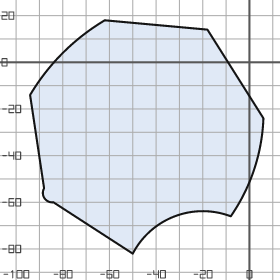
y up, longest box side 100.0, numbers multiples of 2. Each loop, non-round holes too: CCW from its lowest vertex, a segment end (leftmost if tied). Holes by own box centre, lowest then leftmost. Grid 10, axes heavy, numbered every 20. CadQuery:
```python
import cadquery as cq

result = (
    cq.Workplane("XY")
    .moveTo(-50.0, -82.0)
    .threePointArc((-32.0, -66.0), (-8.0, -66.0))
    .threePointArc((2.0, -46.0), (6.0, -24.0))
    .lineTo(-18.0, 14.0)
    .lineTo(-62.0, 18.0)
    .threePointArc((-80.0, 4.0), (-94.0, -14.0))
    .lineTo(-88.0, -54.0)
    .threePointArc((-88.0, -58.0), (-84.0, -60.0))
    .close()
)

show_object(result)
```